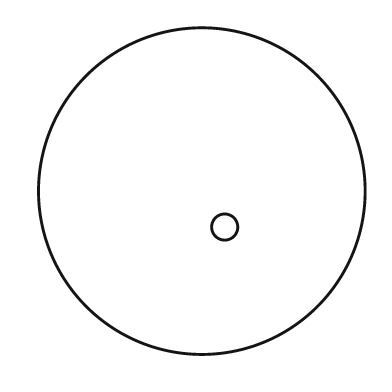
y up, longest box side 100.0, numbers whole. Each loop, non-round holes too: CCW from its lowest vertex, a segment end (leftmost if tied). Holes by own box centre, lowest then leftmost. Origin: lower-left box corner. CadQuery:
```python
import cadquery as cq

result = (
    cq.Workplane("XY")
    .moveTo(50.0, 50.0)
    .circle(50.0)
    .moveTo(57.0, 39.0)
    .circle(4.0)
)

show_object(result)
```